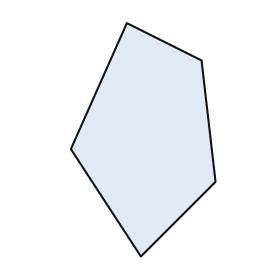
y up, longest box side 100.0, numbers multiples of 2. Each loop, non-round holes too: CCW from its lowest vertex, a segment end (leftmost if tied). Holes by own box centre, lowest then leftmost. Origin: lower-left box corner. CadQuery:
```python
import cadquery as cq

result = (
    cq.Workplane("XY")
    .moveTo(30.0, 0.0)
    .lineTo(62.0, 32.0)
    .lineTo(56.0, 84.0)
    .lineTo(24.0, 100.0)
    .lineTo(0.0, 46.0)
    .close()
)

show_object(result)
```